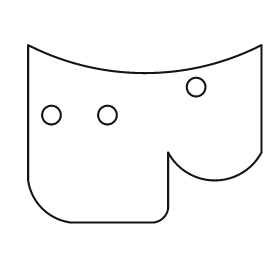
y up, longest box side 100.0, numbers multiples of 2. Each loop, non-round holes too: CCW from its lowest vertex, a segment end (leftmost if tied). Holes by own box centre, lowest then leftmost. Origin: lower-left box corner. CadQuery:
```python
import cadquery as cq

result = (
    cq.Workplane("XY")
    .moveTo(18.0, 0.0)
    .lineTo(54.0, 0.0)
    .threePointArc((58.0, 2.0), (60.0, 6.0))
    .lineTo(60.0, 30.0)
    .threePointArc((80.0, 18.0), (100.0, 30.0))
    .lineTo(100.0, 76.0)
    .threePointArc((50.0, 64.0), (0.0, 76.0))
    .lineTo(0.0, 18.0)
    .threePointArc((6.0, 6.0), (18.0, 0.0))
    .close()
    .moveTo(10.0, 46.0)
    .circle(4.0)
    .moveTo(34.0, 46.0)
    .circle(4.0)
    .moveTo(72.0, 58.0)
    .circle(4.0)
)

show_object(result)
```